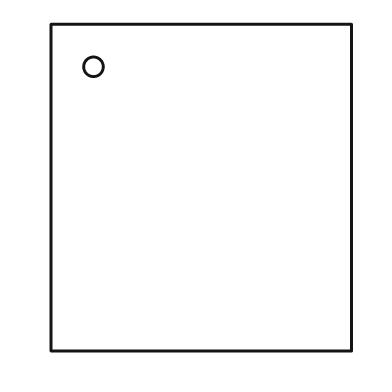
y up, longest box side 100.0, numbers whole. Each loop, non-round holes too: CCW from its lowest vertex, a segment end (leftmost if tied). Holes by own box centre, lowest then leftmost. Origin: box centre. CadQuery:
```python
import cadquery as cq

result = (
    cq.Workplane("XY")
    .moveTo(-46.0, -50.0)
    .lineTo(46.0, -50.0)
    .lineTo(46.0, 50.0)
    .lineTo(-46.0, 50.0)
    .close()
    .moveTo(-33.0, 37.0)
    .circle(3.0)
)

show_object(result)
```